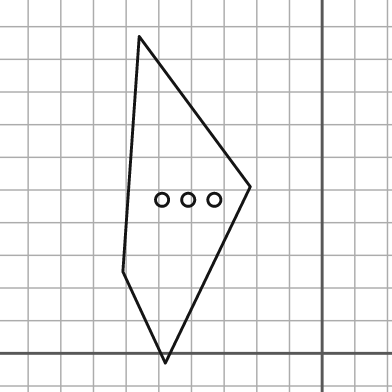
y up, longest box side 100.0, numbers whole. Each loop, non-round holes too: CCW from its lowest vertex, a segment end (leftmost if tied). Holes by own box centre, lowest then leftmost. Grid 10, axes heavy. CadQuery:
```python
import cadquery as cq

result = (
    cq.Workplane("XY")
    .moveTo(-48.0, -3.0)
    .lineTo(-22.0, 51.0)
    .lineTo(-56.0, 97.0)
    .lineTo(-61.0, 25.0)
    .close()
    .moveTo(-49.0, 47.0)
    .circle(2.0)
    .moveTo(-41.0, 47.0)
    .circle(2.0)
    .moveTo(-33.0, 47.0)
    .circle(2.0)
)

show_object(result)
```